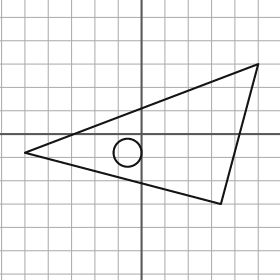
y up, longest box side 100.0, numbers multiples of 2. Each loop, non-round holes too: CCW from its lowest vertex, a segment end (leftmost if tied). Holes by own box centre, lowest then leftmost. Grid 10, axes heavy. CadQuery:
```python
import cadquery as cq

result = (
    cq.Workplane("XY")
    .moveTo(34.0, -30.0)
    .lineTo(50.0, 30.0)
    .lineTo(-50.0, -8.0)
    .close()
    .moveTo(-6.0, -8.0)
    .circle(6.0)
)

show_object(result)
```